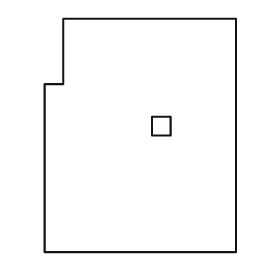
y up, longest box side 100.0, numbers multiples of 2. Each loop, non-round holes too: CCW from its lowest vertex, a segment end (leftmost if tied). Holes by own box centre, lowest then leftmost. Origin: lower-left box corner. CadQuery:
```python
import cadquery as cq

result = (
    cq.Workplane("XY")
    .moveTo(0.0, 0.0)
    .lineTo(82.0, 0.0)
    .lineTo(82.0, 100.0)
    .lineTo(8.0, 100.0)
    .lineTo(8.0, 72.0)
    .lineTo(0.0, 72.0)
    .close()
    .moveTo(46.0, 50.0)
    .lineTo(54.0, 50.0)
    .lineTo(54.0, 58.0)
    .lineTo(46.0, 58.0)
    .close()
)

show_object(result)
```